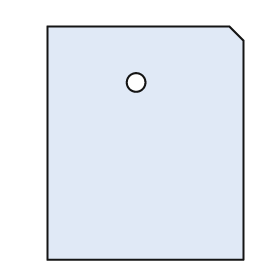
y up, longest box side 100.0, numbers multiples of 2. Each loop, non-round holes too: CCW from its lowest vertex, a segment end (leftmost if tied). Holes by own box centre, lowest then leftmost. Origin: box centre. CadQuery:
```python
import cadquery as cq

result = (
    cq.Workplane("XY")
    .moveTo(-42.0, -50.0)
    .lineTo(42.0, -50.0)
    .lineTo(42.0, 44.0)
    .lineTo(36.0, 50.0)
    .lineTo(-42.0, 50.0)
    .close()
    .moveTo(-4.0, 26.0)
    .circle(4.0)
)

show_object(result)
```